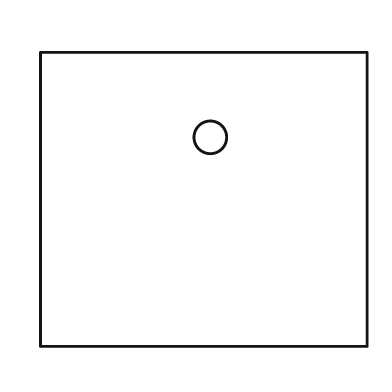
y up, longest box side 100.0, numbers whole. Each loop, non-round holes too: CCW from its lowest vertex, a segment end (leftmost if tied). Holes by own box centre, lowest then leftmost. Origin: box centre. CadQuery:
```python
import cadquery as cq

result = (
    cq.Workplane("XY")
    .moveTo(-50.0, -45.0)
    .lineTo(50.0, -45.0)
    .lineTo(50.0, 45.0)
    .lineTo(-50.0, 45.0)
    .close()
    .moveTo(2.0, 19.0)
    .circle(5.0)
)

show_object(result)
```